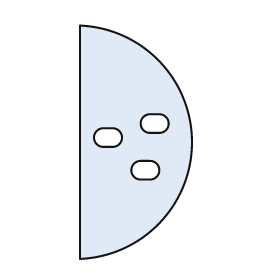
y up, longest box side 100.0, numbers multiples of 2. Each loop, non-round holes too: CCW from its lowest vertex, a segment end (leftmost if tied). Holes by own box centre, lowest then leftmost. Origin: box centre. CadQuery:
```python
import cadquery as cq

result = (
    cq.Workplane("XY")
    .moveTo(-24.0, -50.0)
    .threePointArc((24.0, 0.0), (-24.0, 50.0))
    .close()
    .moveTo(2.0, -16.0)
    .lineTo(6.0, -16.0)
    .threePointArc((10.0, -12.0), (6.0, -8.0))
    .lineTo(2.0, -8.0)
    .threePointArc((-2.0, -12.0), (2.0, -16.0))
    .close()
    .moveTo(-14.0, -2.0)
    .lineTo(-10.0, -2.0)
    .threePointArc((-6.0, 2.0), (-10.0, 6.0))
    .lineTo(-14.0, 6.0)
    .threePointArc((-18.0, 2.0), (-14.0, -2.0))
    .close()
    .moveTo(6.0, 4.0)
    .lineTo(10.0, 4.0)
    .threePointArc((14.0, 8.0), (10.0, 12.0))
    .lineTo(6.0, 12.0)
    .threePointArc((2.0, 8.0), (6.0, 4.0))
    .close()
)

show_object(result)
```